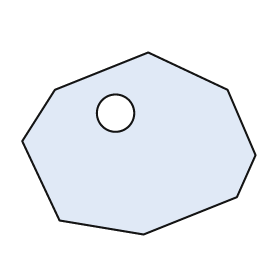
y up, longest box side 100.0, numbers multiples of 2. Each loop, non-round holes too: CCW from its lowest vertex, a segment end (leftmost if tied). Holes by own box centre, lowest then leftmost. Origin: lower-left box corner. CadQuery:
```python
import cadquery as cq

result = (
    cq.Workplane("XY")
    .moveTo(52.0, 0.0)
    .lineTo(92.0, 16.0)
    .lineTo(100.0, 34.0)
    .lineTo(88.0, 62.0)
    .lineTo(54.0, 78.0)
    .lineTo(14.0, 62.0)
    .lineTo(0.0, 40.0)
    .lineTo(16.0, 6.0)
    .close()
    .moveTo(40.0, 52.0)
    .circle(8.0)
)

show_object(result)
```